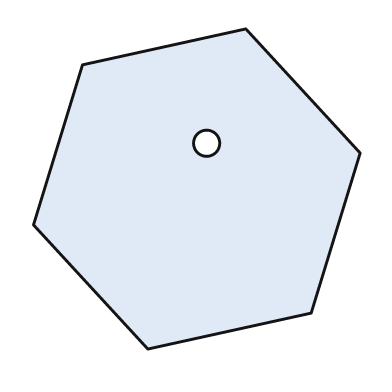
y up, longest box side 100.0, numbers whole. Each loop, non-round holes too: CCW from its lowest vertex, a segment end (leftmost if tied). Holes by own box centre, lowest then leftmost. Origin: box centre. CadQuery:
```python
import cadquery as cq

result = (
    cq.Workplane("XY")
    .moveTo(-15.0, -49.0)
    .lineTo(35.0, -38.0)
    .lineTo(50.0, 11.0)
    .lineTo(15.0, 49.0)
    .lineTo(-35.0, 38.0)
    .lineTo(-50.0, -11.0)
    .close()
    .moveTo(3.0, 14.0)
    .circle(4.0)
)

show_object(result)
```